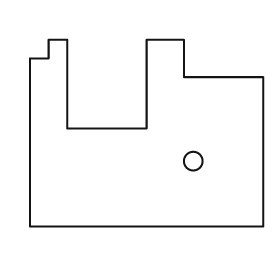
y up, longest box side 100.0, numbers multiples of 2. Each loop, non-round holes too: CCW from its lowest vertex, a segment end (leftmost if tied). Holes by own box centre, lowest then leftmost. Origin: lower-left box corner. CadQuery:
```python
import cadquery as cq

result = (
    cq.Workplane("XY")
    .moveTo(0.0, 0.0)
    .lineTo(100.0, 0.0)
    .lineTo(100.0, 64.0)
    .lineTo(66.0, 64.0)
    .lineTo(66.0, 80.0)
    .lineTo(50.0, 80.0)
    .lineTo(50.0, 42.0)
    .lineTo(16.0, 42.0)
    .lineTo(16.0, 80.0)
    .lineTo(8.0, 80.0)
    .lineTo(8.0, 72.0)
    .lineTo(0.0, 72.0)
    .close()
    .moveTo(70.0, 28.0)
    .circle(4.0)
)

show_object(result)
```